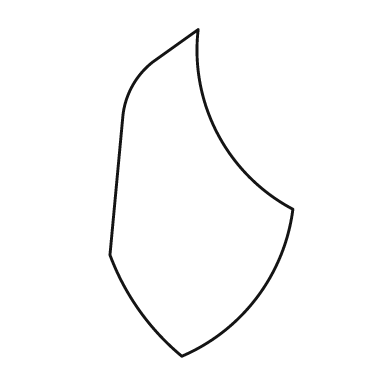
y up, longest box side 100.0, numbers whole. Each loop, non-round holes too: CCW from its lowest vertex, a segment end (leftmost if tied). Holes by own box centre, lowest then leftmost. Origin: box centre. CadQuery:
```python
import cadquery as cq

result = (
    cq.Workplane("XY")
    .moveTo(-6.0, -50.0)
    .threePointArc((17.0, -32.0), (28.0, -5.0))
    .threePointArc((5.0, 18.0), (-1.0, 50.0))
    .lineTo(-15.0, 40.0)
    .threePointArc((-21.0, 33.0), (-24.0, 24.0))
    .lineTo(-28.0, -19.0)
    .threePointArc((-19.0, -36.0), (-6.0, -50.0))
    .close()
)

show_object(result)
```